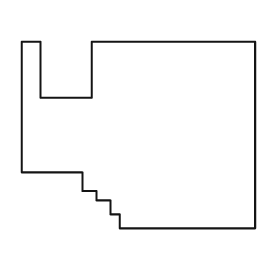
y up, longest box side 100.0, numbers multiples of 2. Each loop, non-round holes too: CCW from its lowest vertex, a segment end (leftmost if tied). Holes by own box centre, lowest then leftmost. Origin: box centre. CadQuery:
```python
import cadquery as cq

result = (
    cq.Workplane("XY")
    .moveTo(-8.0, -40.0)
    .lineTo(50.0, -40.0)
    .lineTo(50.0, 40.0)
    .lineTo(-20.0, 40.0)
    .lineTo(-20.0, 16.0)
    .lineTo(-42.0, 16.0)
    .lineTo(-42.0, 40.0)
    .lineTo(-50.0, 40.0)
    .lineTo(-50.0, -16.0)
    .lineTo(-24.0, -16.0)
    .lineTo(-24.0, -24.0)
    .lineTo(-18.0, -24.0)
    .lineTo(-18.0, -28.0)
    .lineTo(-12.0, -28.0)
    .lineTo(-12.0, -34.0)
    .lineTo(-8.0, -34.0)
    .close()
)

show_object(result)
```